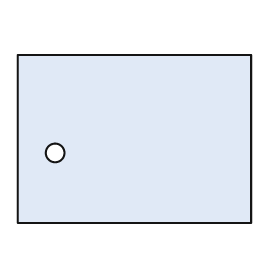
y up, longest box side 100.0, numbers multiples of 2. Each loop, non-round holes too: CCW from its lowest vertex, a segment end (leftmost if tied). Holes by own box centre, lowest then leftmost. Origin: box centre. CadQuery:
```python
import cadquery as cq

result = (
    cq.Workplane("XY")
    .moveTo(-50.0, -36.0)
    .lineTo(50.0, -36.0)
    .lineTo(50.0, 36.0)
    .lineTo(-50.0, 36.0)
    .close()
    .moveTo(-34.0, -6.0)
    .circle(4.0)
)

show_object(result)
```